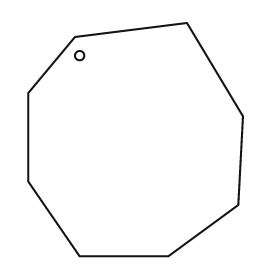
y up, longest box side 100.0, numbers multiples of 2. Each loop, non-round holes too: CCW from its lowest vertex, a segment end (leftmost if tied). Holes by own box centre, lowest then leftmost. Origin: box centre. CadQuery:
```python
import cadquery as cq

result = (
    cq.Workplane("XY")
    .moveTo(-24.0, -50.0)
    .lineTo(14.0, -50.0)
    .lineTo(44.0, -28.0)
    .lineTo(46.0, 10.0)
    .lineTo(22.0, 50.0)
    .lineTo(-26.0, 44.0)
    .lineTo(-46.0, 20.0)
    .lineTo(-46.0, -18.0)
    .close()
    .moveTo(-24.0, 36.0)
    .circle(2.0)
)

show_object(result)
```